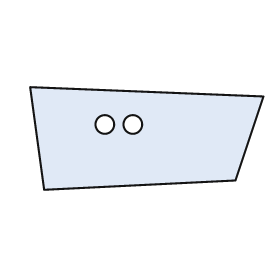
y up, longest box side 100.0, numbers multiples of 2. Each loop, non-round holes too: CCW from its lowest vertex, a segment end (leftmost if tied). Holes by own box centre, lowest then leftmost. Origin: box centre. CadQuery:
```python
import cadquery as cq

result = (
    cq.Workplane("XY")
    .moveTo(-44.0, -22.0)
    .lineTo(38.0, -18.0)
    .lineTo(50.0, 18.0)
    .lineTo(-50.0, 22.0)
    .close()
    .moveTo(-18.0, 6.0)
    .circle(4.0)
    .moveTo(-6.0, 6.0)
    .circle(4.0)
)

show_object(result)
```